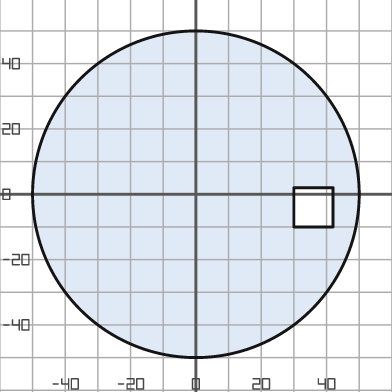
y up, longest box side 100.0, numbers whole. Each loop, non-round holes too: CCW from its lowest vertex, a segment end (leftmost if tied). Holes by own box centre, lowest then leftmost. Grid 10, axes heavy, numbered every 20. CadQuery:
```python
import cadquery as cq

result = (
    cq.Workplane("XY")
    .moveTo(0.0, 0.0)
    .circle(50.0)
    .moveTo(30.0, -10.0)
    .lineTo(42.0, -10.0)
    .lineTo(42.0, 2.0)
    .lineTo(30.0, 2.0)
    .close()
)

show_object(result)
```